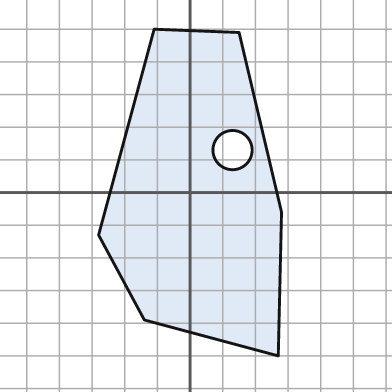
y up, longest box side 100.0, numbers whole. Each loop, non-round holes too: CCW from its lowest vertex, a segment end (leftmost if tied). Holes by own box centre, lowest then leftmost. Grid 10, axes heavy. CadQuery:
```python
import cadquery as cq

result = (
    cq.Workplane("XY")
    .moveTo(27.0, -50.0)
    .lineTo(28.0, -6.0)
    .lineTo(15.0, 49.0)
    .lineTo(-11.0, 50.0)
    .lineTo(-28.0, -13.0)
    .lineTo(-14.0, -39.0)
    .close()
    .moveTo(13.0, 13.0)
    .circle(6.0)
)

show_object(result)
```